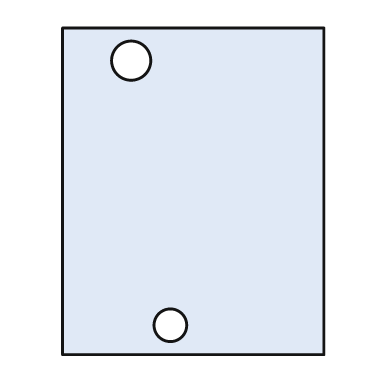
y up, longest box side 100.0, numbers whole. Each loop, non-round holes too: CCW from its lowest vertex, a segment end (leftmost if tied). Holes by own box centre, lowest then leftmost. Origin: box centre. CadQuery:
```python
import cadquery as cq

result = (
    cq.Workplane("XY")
    .moveTo(-40.0, -50.0)
    .lineTo(40.0, -50.0)
    .lineTo(40.0, 50.0)
    .lineTo(-40.0, 50.0)
    .close()
    .moveTo(-7.0, -41.0)
    .circle(5.0)
    .moveTo(-19.0, 40.0)
    .circle(6.0)
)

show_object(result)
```